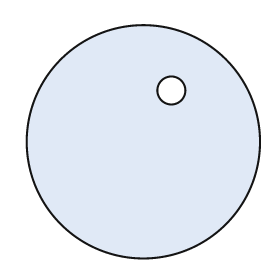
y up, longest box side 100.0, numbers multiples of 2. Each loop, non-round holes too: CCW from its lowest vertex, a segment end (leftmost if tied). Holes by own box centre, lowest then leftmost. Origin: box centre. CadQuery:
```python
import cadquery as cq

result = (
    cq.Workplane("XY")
    .moveTo(0.0, 0.0)
    .circle(50.0)
    .moveTo(12.0, 22.0)
    .circle(6.0)
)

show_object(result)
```